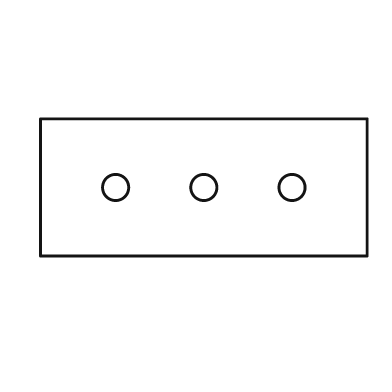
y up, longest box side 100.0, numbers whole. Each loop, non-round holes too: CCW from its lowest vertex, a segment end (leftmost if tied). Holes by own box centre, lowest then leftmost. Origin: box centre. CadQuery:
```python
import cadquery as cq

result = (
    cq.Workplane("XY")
    .moveTo(-50.0, -21.0)
    .lineTo(50.0, -21.0)
    .lineTo(50.0, 21.0)
    .lineTo(-50.0, 21.0)
    .close()
    .moveTo(-27.0, 0.0)
    .circle(4.0)
    .moveTo(0.0, 0.0)
    .circle(4.0)
    .moveTo(27.0, 0.0)
    .circle(4.0)
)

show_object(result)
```